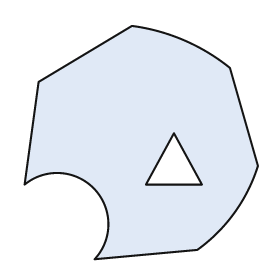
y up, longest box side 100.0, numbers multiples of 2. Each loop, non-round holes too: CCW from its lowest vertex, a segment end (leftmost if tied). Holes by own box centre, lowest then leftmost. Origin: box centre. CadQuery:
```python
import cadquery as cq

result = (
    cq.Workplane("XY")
    .moveTo(-20.0, -50.0)
    .lineTo(24.0, -46.0)
    .threePointArc((40.0, -30.0), (50.0, -10.0))
    .lineTo(38.0, 32.0)
    .threePointArc((18.0, 44.0), (-4.0, 50.0))
    .lineTo(-44.0, 26.0)
    .lineTo(-50.0, -18.0)
    .threePointArc((-20.0, -20.0), (-20.0, -50.0))
    .close()
    .moveTo(2.0, -18.0)
    .lineTo(26.0, -18.0)
    .lineTo(14.0, 4.0)
    .close()
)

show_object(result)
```